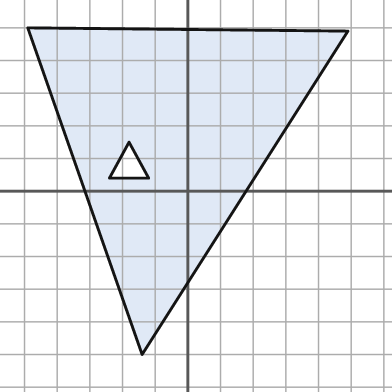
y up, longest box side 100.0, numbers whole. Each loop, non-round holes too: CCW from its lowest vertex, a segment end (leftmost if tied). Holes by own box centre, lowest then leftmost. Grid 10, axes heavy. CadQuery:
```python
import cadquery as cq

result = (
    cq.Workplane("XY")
    .moveTo(-14.0, -50.0)
    .lineTo(49.0, 49.0)
    .lineTo(-49.0, 50.0)
    .close()
    .moveTo(-24.0, 4.0)
    .lineTo(-12.0, 4.0)
    .lineTo(-18.0, 15.0)
    .close()
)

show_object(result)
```